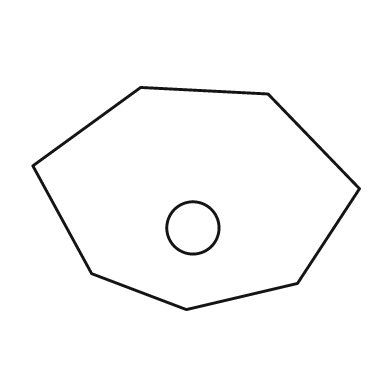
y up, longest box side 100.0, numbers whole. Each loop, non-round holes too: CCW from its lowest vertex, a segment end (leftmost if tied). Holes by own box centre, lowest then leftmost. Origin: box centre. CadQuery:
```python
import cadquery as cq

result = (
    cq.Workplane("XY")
    .moveTo(-3.0, -34.0)
    .lineTo(31.0, -26.0)
    .lineTo(50.0, 3.0)
    .lineTo(22.0, 32.0)
    .lineTo(-17.0, 34.0)
    .lineTo(-50.0, 10.0)
    .lineTo(-32.0, -23.0)
    .close()
    .moveTo(-1.0, -9.0)
    .circle(8.0)
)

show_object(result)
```